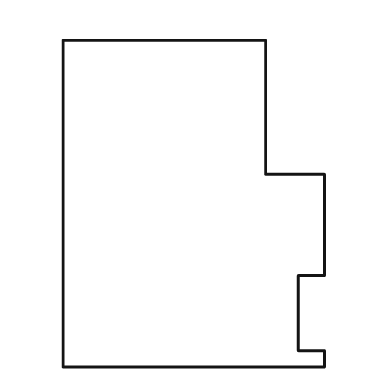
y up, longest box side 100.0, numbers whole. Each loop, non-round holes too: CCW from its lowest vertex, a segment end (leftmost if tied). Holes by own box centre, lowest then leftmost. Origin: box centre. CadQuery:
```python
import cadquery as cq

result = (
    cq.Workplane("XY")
    .moveTo(-40.0, -50.0)
    .lineTo(40.0, -50.0)
    .lineTo(40.0, -45.0)
    .lineTo(32.0, -45.0)
    .lineTo(32.0, -22.0)
    .lineTo(40.0, -22.0)
    .lineTo(40.0, 9.0)
    .lineTo(22.0, 9.0)
    .lineTo(22.0, 50.0)
    .lineTo(-40.0, 50.0)
    .close()
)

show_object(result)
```